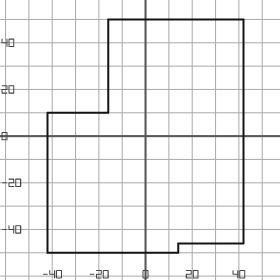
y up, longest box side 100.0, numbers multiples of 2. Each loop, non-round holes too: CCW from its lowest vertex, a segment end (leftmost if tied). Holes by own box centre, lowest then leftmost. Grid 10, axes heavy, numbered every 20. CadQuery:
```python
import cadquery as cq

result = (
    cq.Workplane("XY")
    .moveTo(-42.0, -50.0)
    .lineTo(14.0, -50.0)
    .lineTo(14.0, -46.0)
    .lineTo(42.0, -46.0)
    .lineTo(42.0, 50.0)
    .lineTo(-16.0, 50.0)
    .lineTo(-16.0, 10.0)
    .lineTo(-42.0, 10.0)
    .close()
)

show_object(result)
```